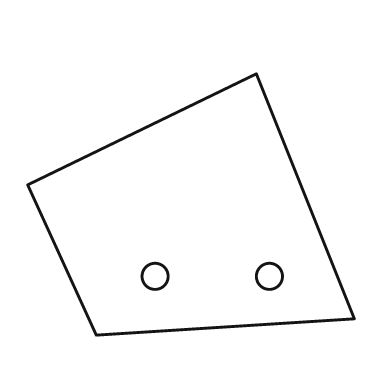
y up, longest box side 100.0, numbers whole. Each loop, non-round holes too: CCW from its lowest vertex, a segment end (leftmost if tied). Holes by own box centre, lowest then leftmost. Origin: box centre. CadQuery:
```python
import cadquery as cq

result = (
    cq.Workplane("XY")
    .moveTo(-29.0, -40.0)
    .lineTo(50.0, -35.0)
    .lineTo(20.0, 40.0)
    .lineTo(-50.0, 6.0)
    .close()
    .moveTo(-11.0, -22.0)
    .circle(4.0)
    .moveTo(24.0, -22.0)
    .circle(4.0)
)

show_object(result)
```